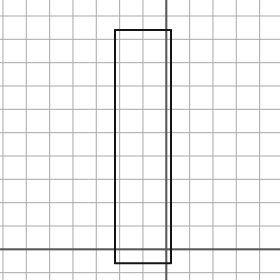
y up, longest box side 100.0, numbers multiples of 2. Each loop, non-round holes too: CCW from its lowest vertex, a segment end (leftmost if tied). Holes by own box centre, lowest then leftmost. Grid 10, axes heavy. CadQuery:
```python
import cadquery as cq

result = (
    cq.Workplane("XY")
    .moveTo(-22.0, -6.0)
    .lineTo(2.0, -6.0)
    .lineTo(2.0, 94.0)
    .lineTo(-22.0, 94.0)
    .close()
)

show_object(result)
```